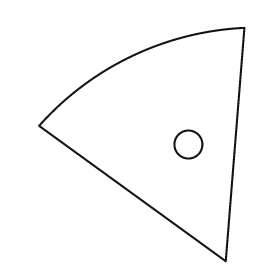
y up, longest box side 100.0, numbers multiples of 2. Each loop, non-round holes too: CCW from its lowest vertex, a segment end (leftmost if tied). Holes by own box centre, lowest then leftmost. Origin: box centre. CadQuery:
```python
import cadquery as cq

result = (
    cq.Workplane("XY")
    .moveTo(36.0, -50.0)
    .lineTo(44.0, 50.0)
    .threePointArc((-4.0, 38.0), (-44.0, 8.0))
    .close()
    .moveTo(20.0, 0.0)
    .circle(6.0)
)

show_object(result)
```